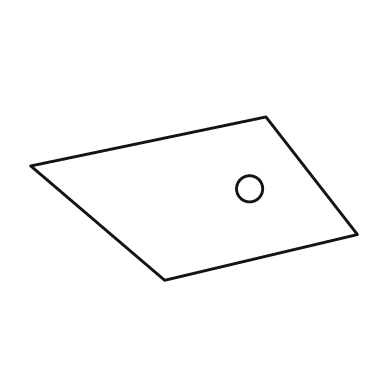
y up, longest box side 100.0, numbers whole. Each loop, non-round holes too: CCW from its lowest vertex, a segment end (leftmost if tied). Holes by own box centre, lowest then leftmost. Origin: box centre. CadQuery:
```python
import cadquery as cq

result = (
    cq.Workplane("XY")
    .moveTo(-9.0, -25.0)
    .lineTo(50.0, -11.0)
    .lineTo(22.0, 25.0)
    .lineTo(-50.0, 10.0)
    .close()
    .moveTo(17.0, 3.0)
    .circle(4.0)
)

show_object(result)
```